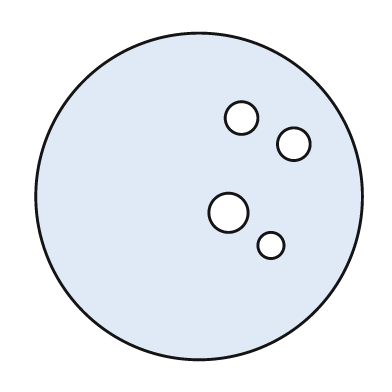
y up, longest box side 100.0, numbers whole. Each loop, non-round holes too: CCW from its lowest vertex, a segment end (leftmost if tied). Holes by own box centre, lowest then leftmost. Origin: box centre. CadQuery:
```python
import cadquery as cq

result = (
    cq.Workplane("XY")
    .moveTo(0.0, 0.0)
    .circle(50.0)
    .moveTo(22.0, -15.0)
    .circle(4.0)
    .moveTo(9.0, -5.0)
    .circle(6.0)
    .moveTo(29.0, 16.0)
    .circle(5.0)
    .moveTo(13.0, 24.0)
    .circle(5.0)
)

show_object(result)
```